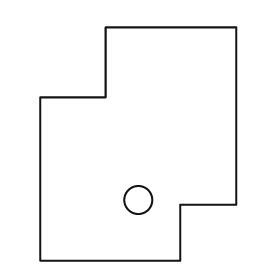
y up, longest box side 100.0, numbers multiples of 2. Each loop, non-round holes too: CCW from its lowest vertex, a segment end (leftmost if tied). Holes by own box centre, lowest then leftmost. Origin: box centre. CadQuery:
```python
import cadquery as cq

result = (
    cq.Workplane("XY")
    .moveTo(-42.0, -50.0)
    .lineTo(18.0, -50.0)
    .lineTo(18.0, -26.0)
    .lineTo(42.0, -26.0)
    .lineTo(42.0, 50.0)
    .lineTo(-14.0, 50.0)
    .lineTo(-14.0, 20.0)
    .lineTo(-42.0, 20.0)
    .close()
    .moveTo(0.0, -24.0)
    .circle(6.0)
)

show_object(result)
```